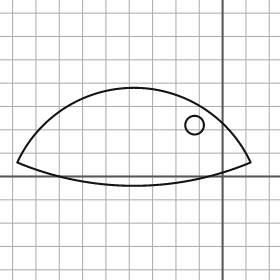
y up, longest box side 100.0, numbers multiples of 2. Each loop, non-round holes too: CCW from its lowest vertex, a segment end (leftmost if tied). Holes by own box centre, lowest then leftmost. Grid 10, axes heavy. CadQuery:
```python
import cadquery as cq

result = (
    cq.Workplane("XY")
    .moveTo(-88.0, 6.0)
    .threePointArc((-38.0, -4.0), (12.0, 6.0))
    .threePointArc((-38.0, 38.0), (-88.0, 6.0))
    .close()
    .moveTo(-12.0, 22.0)
    .circle(4.0)
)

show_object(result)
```